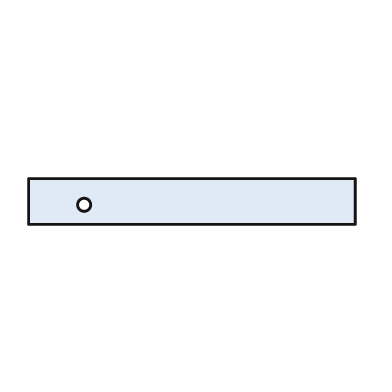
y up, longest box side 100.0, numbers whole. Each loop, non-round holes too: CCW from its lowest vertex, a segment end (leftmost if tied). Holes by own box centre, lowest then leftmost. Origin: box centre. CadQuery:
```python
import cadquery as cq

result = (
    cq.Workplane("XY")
    .moveTo(-50.0, -7.0)
    .lineTo(50.0, -7.0)
    .lineTo(50.0, 7.0)
    .lineTo(-50.0, 7.0)
    .close()
    .moveTo(-33.0, -1.0)
    .circle(2.0)
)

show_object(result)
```